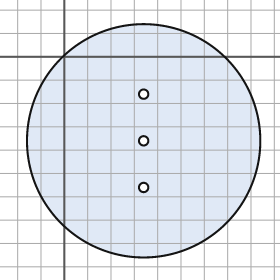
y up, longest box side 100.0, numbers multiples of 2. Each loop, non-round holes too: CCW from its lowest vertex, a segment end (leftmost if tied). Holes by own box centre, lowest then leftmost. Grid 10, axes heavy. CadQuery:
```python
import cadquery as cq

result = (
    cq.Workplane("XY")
    .moveTo(34.0, -36.0)
    .circle(50.0)
    .moveTo(34.0, -56.0)
    .circle(2.0)
    .moveTo(34.0, -36.0)
    .circle(2.0)
    .moveTo(34.0, -16.0)
    .circle(2.0)
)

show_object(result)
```